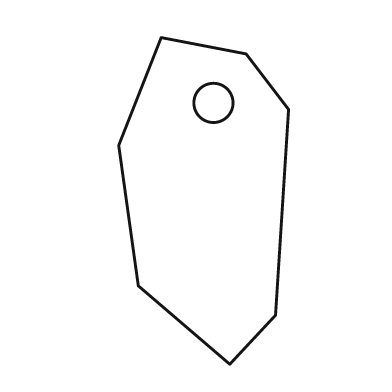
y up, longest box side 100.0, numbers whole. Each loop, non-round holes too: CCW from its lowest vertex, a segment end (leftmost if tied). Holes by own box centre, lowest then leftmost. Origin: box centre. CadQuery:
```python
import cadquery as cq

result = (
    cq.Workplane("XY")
    .moveTo(8.0, -50.0)
    .lineTo(22.0, -35.0)
    .lineTo(26.0, 28.0)
    .lineTo(13.0, 45.0)
    .lineTo(-13.0, 50.0)
    .lineTo(-26.0, 17.0)
    .lineTo(-20.0, -26.0)
    .close()
    .moveTo(3.0, 30.0)
    .circle(6.0)
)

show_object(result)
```